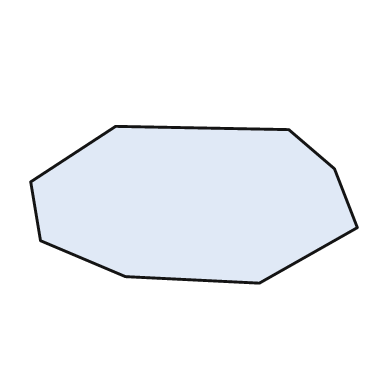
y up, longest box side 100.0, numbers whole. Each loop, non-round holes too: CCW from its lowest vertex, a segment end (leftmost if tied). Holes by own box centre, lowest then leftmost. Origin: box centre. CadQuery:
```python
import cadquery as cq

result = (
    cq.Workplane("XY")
    .moveTo(20.0, -24.0)
    .lineTo(50.0, -7.0)
    .lineTo(43.0, 11.0)
    .lineTo(29.0, 23.0)
    .lineTo(-24.0, 24.0)
    .lineTo(-50.0, 7.0)
    .lineTo(-47.0, -11.0)
    .lineTo(-21.0, -22.0)
    .close()
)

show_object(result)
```